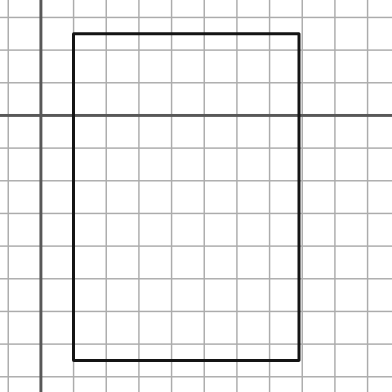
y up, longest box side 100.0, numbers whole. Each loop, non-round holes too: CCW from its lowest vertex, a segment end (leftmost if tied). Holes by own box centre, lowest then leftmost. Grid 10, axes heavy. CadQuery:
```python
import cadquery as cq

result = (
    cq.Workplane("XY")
    .moveTo(10.0, -75.0)
    .lineTo(79.0, -75.0)
    .lineTo(79.0, 25.0)
    .lineTo(10.0, 25.0)
    .close()
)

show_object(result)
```